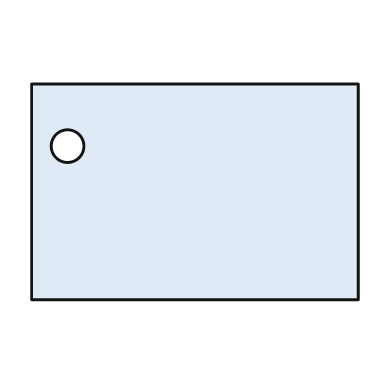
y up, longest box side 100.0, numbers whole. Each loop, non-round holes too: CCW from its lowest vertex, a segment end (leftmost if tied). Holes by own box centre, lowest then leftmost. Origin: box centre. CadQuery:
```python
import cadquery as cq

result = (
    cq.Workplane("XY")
    .moveTo(-50.0, -33.0)
    .lineTo(50.0, -33.0)
    .lineTo(50.0, 33.0)
    .lineTo(-50.0, 33.0)
    .close()
    .moveTo(-39.0, 14.0)
    .circle(5.0)
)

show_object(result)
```